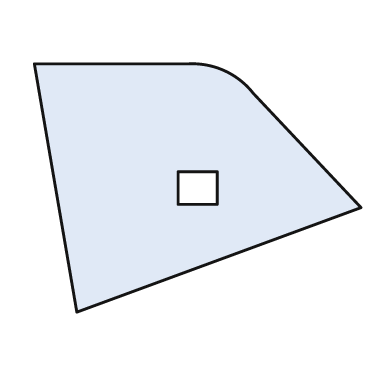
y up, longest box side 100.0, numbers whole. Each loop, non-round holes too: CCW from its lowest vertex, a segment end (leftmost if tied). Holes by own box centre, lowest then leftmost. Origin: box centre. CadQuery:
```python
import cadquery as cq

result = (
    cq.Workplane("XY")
    .moveTo(-37.0, -38.0)
    .lineTo(50.0, -6.0)
    .lineTo(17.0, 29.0)
    .threePointArc((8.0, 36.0), (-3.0, 38.0))
    .lineTo(-50.0, 38.0)
    .close()
    .moveTo(-6.0, -5.0)
    .lineTo(6.0, -5.0)
    .lineTo(6.0, 5.0)
    .lineTo(-6.0, 5.0)
    .close()
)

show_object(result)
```